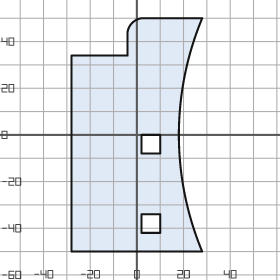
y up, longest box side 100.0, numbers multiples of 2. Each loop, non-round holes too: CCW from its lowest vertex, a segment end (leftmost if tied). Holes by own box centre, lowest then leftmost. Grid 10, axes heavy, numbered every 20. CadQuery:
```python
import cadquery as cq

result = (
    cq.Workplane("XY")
    .moveTo(-28.0, -50.0)
    .lineTo(28.0, -50.0)
    .threePointArc((18.0, 0.0), (28.0, 50.0))
    .lineTo(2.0, 50.0)
    .threePointArc((-2.0, 48.0), (-4.0, 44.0))
    .lineTo(-4.0, 34.0)
    .lineTo(-28.0, 34.0)
    .close()
    .moveTo(2.0, -42.0)
    .lineTo(10.0, -42.0)
    .lineTo(10.0, -34.0)
    .lineTo(2.0, -34.0)
    .close()
    .moveTo(2.0, -8.0)
    .lineTo(10.0, -8.0)
    .lineTo(10.0, 0.0)
    .lineTo(2.0, 0.0)
    .close()
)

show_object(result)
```